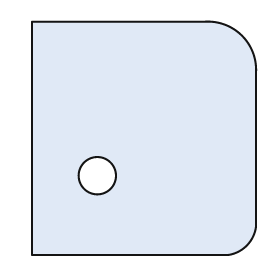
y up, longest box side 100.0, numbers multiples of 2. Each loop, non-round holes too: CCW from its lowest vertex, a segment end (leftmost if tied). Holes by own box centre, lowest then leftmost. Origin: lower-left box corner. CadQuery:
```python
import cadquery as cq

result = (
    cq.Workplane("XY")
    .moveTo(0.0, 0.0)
    .lineTo(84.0, 0.0)
    .threePointArc((92.0, 4.0), (96.0, 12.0))
    .lineTo(96.0, 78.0)
    .threePointArc((90.0, 94.0), (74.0, 100.0))
    .lineTo(0.0, 100.0)
    .close()
    .moveTo(28.0, 34.0)
    .circle(8.0)
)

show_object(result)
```